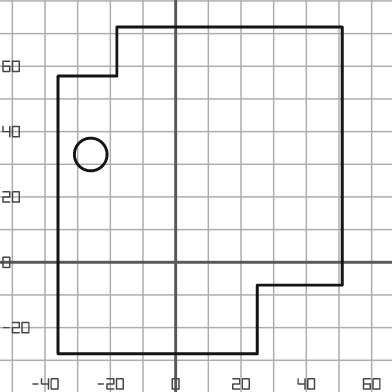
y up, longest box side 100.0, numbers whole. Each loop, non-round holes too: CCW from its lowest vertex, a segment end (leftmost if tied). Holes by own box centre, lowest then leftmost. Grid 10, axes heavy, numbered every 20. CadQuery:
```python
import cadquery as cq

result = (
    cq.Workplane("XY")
    .moveTo(-36.0, -28.0)
    .lineTo(25.0, -28.0)
    .lineTo(25.0, -7.0)
    .lineTo(51.0, -7.0)
    .lineTo(51.0, 72.0)
    .lineTo(-18.0, 72.0)
    .lineTo(-18.0, 57.0)
    .lineTo(-36.0, 57.0)
    .close()
    .moveTo(-26.0, 33.0)
    .circle(5.0)
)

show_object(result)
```